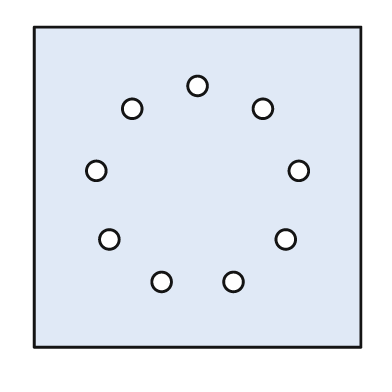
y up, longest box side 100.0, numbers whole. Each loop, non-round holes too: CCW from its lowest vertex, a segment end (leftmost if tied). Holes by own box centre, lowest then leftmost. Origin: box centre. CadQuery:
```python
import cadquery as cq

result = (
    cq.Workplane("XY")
    .moveTo(-50.0, -49.0)
    .lineTo(50.0, -49.0)
    .lineTo(50.0, 49.0)
    .lineTo(-50.0, 49.0)
    .close()
    .moveTo(-11.0, -29.0)
    .circle(3.0)
    .moveTo(11.0, -29.0)
    .circle(3.0)
    .moveTo(-27.0, -16.0)
    .circle(3.0)
    .moveTo(27.0, -16.0)
    .circle(3.0)
    .moveTo(-31.0, 5.0)
    .circle(3.0)
    .moveTo(31.0, 5.0)
    .circle(3.0)
    .moveTo(-20.0, 24.0)
    .circle(3.0)
    .moveTo(20.0, 24.0)
    .circle(3.0)
    .moveTo(0.0, 31.0)
    .circle(3.0)
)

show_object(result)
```